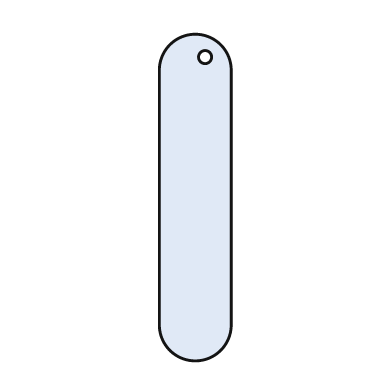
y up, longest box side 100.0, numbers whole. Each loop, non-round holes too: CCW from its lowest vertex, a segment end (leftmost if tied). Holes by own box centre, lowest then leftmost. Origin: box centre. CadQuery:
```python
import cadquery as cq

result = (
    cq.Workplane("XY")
    .moveTo(-11.0, -39.0)
    .threePointArc((0.0, -50.0), (11.0, -39.0))
    .lineTo(11.0, 39.0)
    .threePointArc((0.0, 50.0), (-11.0, 39.0))
    .close()
    .moveTo(3.0, 43.0)
    .circle(2.0)
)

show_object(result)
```